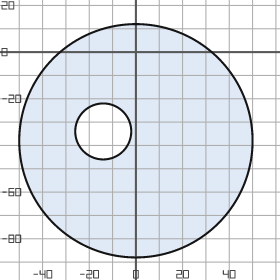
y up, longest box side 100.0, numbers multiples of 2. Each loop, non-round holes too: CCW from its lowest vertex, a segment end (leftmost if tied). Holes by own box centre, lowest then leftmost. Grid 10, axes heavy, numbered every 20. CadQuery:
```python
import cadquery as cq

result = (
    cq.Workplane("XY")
    .moveTo(0.0, -38.0)
    .circle(50.0)
    .moveTo(-14.0, -34.0)
    .circle(12.0)
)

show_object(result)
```